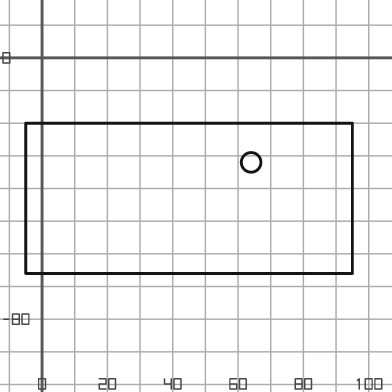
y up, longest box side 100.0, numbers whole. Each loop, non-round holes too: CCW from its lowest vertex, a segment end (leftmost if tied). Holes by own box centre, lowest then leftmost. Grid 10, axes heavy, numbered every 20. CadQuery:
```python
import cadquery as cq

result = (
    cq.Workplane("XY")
    .moveTo(-5.0, -66.0)
    .lineTo(95.0, -66.0)
    .lineTo(95.0, -20.0)
    .lineTo(-5.0, -20.0)
    .close()
    .moveTo(64.0, -32.0)
    .circle(3.0)
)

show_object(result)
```